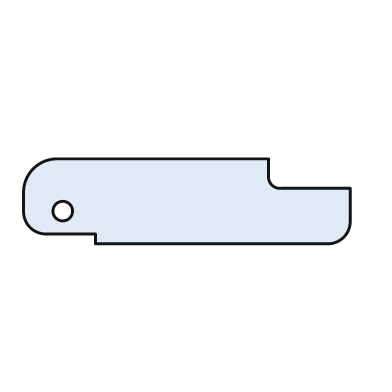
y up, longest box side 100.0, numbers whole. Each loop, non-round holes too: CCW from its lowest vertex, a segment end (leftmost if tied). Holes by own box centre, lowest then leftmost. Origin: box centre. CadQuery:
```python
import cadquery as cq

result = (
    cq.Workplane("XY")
    .moveTo(-28.0, -13.0)
    .lineTo(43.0, -13.0)
    .threePointArc((48.0, -11.0), (50.0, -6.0))
    .lineTo(50.0, 4.0)
    .lineTo(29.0, 4.0)
    .threePointArc((26.0, 5.0), (25.0, 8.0))
    .lineTo(25.0, 13.0)
    .lineTo(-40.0, 13.0)
    .threePointArc((-47.0, 10.0), (-50.0, 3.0))
    .lineTo(-50.0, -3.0)
    .threePointArc((-48.0, -8.0), (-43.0, -10.0))
    .lineTo(-28.0, -10.0)
    .close()
    .moveTo(-38.0, -3.0)
    .circle(3.0)
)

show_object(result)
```